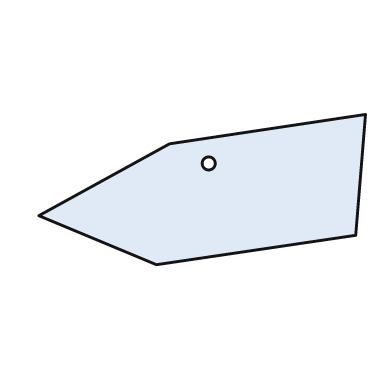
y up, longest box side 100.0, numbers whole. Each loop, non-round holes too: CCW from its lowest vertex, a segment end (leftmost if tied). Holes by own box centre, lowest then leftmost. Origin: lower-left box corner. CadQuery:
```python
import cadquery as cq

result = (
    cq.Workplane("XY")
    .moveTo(36.0, 0.0)
    .lineTo(97.0, 9.0)
    .lineTo(100.0, 46.0)
    .lineTo(40.0, 37.0)
    .lineTo(0.0, 15.0)
    .close()
    .moveTo(52.0, 31.0)
    .circle(2.0)
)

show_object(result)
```